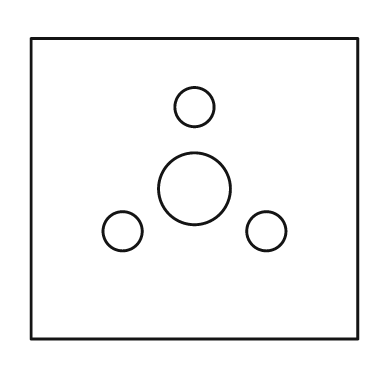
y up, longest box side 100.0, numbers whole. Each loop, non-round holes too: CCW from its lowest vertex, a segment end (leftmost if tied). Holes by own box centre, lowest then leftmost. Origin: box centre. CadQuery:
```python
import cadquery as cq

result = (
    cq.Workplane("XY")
    .moveTo(-50.0, -46.0)
    .lineTo(50.0, -46.0)
    .lineTo(50.0, 46.0)
    .lineTo(-50.0, 46.0)
    .close()
    .moveTo(-22.0, -13.0)
    .circle(6.0)
    .moveTo(22.0, -13.0)
    .circle(6.0)
    .moveTo(0.0, 0.0)
    .circle(11.0)
    .moveTo(0.0, 25.0)
    .circle(6.0)
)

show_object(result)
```